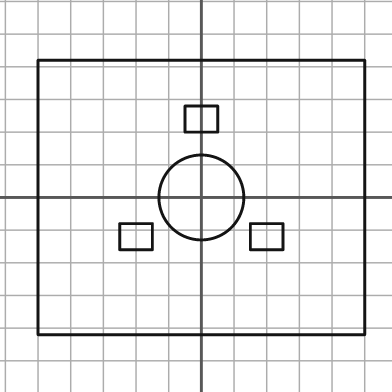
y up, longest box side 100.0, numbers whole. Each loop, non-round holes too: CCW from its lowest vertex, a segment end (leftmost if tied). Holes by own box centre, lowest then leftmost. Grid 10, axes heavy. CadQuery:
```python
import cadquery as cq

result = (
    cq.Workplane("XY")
    .moveTo(-50.0, -42.0)
    .lineTo(50.0, -42.0)
    .lineTo(50.0, 42.0)
    .lineTo(-50.0, 42.0)
    .close()
    .moveTo(-25.0, -16.0)
    .lineTo(-15.0, -16.0)
    .lineTo(-15.0, -8.0)
    .lineTo(-25.0, -8.0)
    .close()
    .moveTo(15.0, -16.0)
    .lineTo(25.0, -16.0)
    .lineTo(25.0, -8.0)
    .lineTo(15.0, -8.0)
    .close()
    .moveTo(0.0, 0.0)
    .circle(13.0)
    .moveTo(-5.0, 20.0)
    .lineTo(5.0, 20.0)
    .lineTo(5.0, 28.0)
    .lineTo(-5.0, 28.0)
    .close()
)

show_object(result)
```